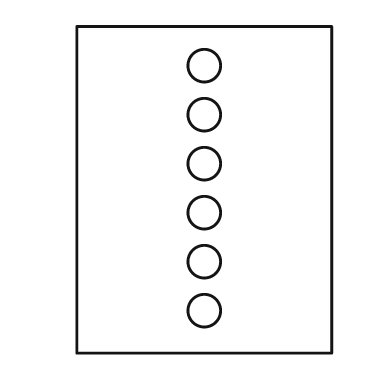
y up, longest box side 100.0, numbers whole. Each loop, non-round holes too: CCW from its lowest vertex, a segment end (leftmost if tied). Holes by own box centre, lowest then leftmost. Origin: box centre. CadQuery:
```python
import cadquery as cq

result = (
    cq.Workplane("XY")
    .moveTo(-39.0, -50.0)
    .lineTo(39.0, -50.0)
    .lineTo(39.0, 50.0)
    .lineTo(-39.0, 50.0)
    .close()
    .moveTo(0.0, -37.0)
    .circle(5.0)
    .moveTo(0.0, -22.0)
    .circle(5.0)
    .moveTo(0.0, -7.0)
    .circle(5.0)
    .moveTo(0.0, 8.0)
    .circle(5.0)
    .moveTo(0.0, 23.0)
    .circle(5.0)
    .moveTo(0.0, 38.0)
    .circle(5.0)
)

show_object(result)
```